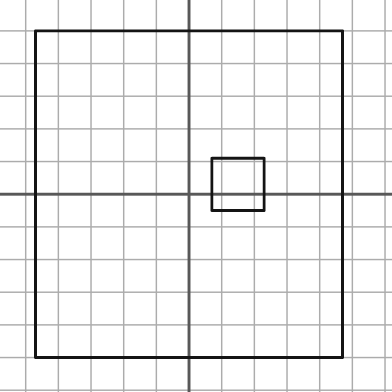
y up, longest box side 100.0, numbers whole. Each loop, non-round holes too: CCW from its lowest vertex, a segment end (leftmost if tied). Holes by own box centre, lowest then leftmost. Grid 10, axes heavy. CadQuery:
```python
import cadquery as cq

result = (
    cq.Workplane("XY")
    .moveTo(-47.0, -50.0)
    .lineTo(47.0, -50.0)
    .lineTo(47.0, 50.0)
    .lineTo(-47.0, 50.0)
    .close()
    .moveTo(7.0, -5.0)
    .lineTo(23.0, -5.0)
    .lineTo(23.0, 11.0)
    .lineTo(7.0, 11.0)
    .close()
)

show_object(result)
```